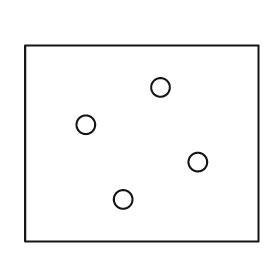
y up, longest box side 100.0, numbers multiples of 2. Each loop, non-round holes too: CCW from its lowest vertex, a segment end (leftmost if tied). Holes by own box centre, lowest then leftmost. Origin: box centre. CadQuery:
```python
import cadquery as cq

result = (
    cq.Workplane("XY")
    .moveTo(-50.0, -42.0)
    .lineTo(50.0, -42.0)
    .lineTo(50.0, 42.0)
    .lineTo(-50.0, 42.0)
    .close()
    .moveTo(-8.0, -24.0)
    .circle(4.0)
    .moveTo(24.0, -8.0)
    .circle(4.0)
    .moveTo(-24.0, 8.0)
    .circle(4.0)
    .moveTo(8.0, 24.0)
    .circle(4.0)
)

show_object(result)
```